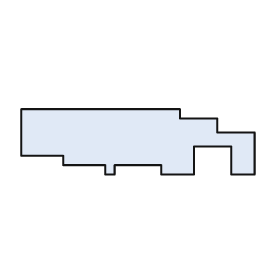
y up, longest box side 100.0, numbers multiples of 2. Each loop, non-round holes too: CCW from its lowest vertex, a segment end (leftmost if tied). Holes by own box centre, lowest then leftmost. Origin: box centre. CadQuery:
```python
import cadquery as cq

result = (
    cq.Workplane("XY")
    .moveTo(-14.0, -14.0)
    .lineTo(-10.0, -14.0)
    .lineTo(-10.0, -10.0)
    .lineTo(10.0, -10.0)
    .lineTo(10.0, -14.0)
    .lineTo(24.0, -14.0)
    .lineTo(24.0, -2.0)
    .lineTo(40.0, -2.0)
    .lineTo(40.0, -14.0)
    .lineTo(50.0, -14.0)
    .lineTo(50.0, 4.0)
    .lineTo(34.0, 4.0)
    .lineTo(34.0, 10.0)
    .lineTo(18.0, 10.0)
    .lineTo(18.0, 14.0)
    .lineTo(-50.0, 14.0)
    .lineTo(-50.0, -6.0)
    .lineTo(-32.0, -6.0)
    .lineTo(-32.0, -10.0)
    .lineTo(-14.0, -10.0)
    .close()
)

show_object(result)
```